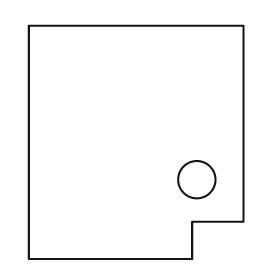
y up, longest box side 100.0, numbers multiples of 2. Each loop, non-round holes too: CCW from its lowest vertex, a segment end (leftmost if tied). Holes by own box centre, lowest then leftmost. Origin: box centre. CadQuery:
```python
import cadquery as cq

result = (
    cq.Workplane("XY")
    .moveTo(-46.0, -50.0)
    .lineTo(24.0, -50.0)
    .lineTo(24.0, -34.0)
    .lineTo(46.0, -34.0)
    .lineTo(46.0, 50.0)
    .lineTo(-46.0, 50.0)
    .close()
    .moveTo(26.0, -16.0)
    .circle(8.0)
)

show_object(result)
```